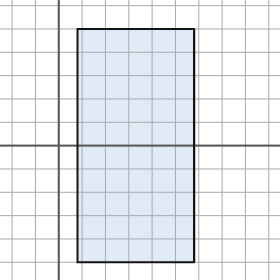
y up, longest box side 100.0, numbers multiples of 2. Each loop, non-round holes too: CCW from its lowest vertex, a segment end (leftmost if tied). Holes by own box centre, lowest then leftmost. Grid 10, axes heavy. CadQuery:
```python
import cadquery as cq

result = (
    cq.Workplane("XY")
    .moveTo(8.0, -50.0)
    .lineTo(58.0, -50.0)
    .lineTo(58.0, 50.0)
    .lineTo(8.0, 50.0)
    .close()
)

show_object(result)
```